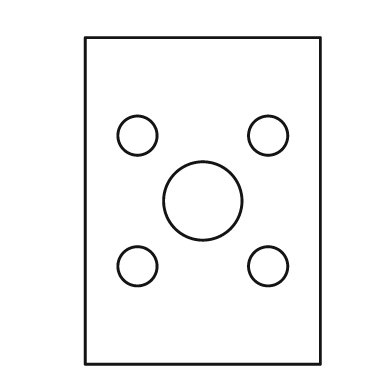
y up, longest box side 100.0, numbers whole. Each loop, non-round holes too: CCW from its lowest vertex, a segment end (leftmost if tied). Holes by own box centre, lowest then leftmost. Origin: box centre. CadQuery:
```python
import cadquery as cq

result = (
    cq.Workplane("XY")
    .moveTo(-36.0, -50.0)
    .lineTo(36.0, -50.0)
    .lineTo(36.0, 50.0)
    .lineTo(-36.0, 50.0)
    .close()
    .moveTo(-20.0, -20.0)
    .circle(6.0)
    .moveTo(20.0, -20.0)
    .circle(6.0)
    .moveTo(0.0, 0.0)
    .circle(12.0)
    .moveTo(-20.0, 20.0)
    .circle(6.0)
    .moveTo(20.0, 20.0)
    .circle(6.0)
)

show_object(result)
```